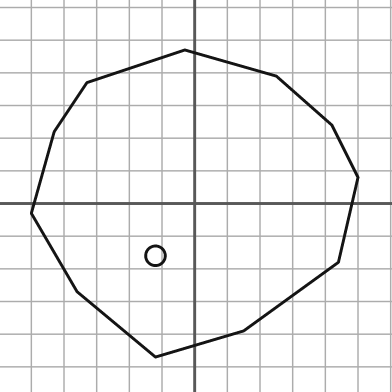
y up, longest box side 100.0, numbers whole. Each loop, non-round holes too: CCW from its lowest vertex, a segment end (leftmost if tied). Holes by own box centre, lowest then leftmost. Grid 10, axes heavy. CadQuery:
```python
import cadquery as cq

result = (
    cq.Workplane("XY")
    .moveTo(-12.0, -47.0)
    .lineTo(15.0, -39.0)
    .lineTo(44.0, -18.0)
    .lineTo(50.0, 8.0)
    .lineTo(42.0, 24.0)
    .lineTo(25.0, 39.0)
    .lineTo(-3.0, 47.0)
    .lineTo(-33.0, 37.0)
    .lineTo(-43.0, 22.0)
    .lineTo(-50.0, -3.0)
    .lineTo(-36.0, -27.0)
    .close()
    .moveTo(-12.0, -16.0)
    .circle(3.0)
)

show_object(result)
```